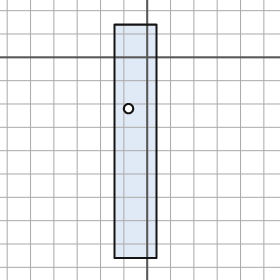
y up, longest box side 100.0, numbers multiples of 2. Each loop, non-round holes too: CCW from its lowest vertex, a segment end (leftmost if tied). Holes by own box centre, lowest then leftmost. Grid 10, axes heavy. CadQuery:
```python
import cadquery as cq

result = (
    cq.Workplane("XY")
    .moveTo(-14.0, -86.0)
    .lineTo(4.0, -86.0)
    .lineTo(4.0, 14.0)
    .lineTo(-14.0, 14.0)
    .close()
    .moveTo(-8.0, -22.0)
    .circle(2.0)
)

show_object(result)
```